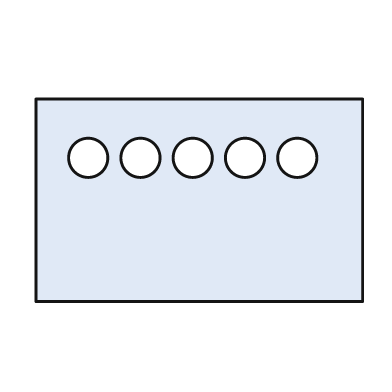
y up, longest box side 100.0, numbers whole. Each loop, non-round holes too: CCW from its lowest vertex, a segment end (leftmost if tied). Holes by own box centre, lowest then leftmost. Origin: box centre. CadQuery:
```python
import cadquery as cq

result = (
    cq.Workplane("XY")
    .moveTo(-50.0, -31.0)
    .lineTo(50.0, -31.0)
    .lineTo(50.0, 31.0)
    .lineTo(-50.0, 31.0)
    .close()
    .moveTo(-34.0, 13.0)
    .circle(6.0)
    .moveTo(-18.0, 13.0)
    .circle(6.0)
    .moveTo(-2.0, 13.0)
    .circle(6.0)
    .moveTo(14.0, 13.0)
    .circle(6.0)
    .moveTo(30.0, 13.0)
    .circle(6.0)
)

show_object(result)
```